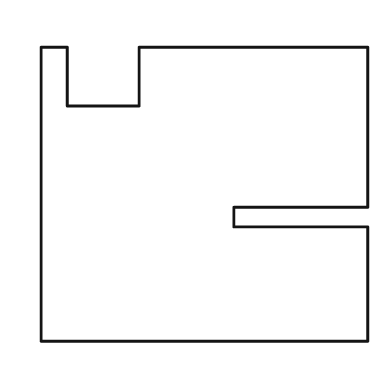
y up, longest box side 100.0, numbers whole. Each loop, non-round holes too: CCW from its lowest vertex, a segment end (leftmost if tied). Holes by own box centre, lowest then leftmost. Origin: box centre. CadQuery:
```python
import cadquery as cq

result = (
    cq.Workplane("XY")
    .moveTo(-50.0, -45.0)
    .lineTo(50.0, -45.0)
    .lineTo(50.0, -10.0)
    .lineTo(9.0, -10.0)
    .lineTo(9.0, -4.0)
    .lineTo(50.0, -4.0)
    .lineTo(50.0, 45.0)
    .lineTo(-20.0, 45.0)
    .lineTo(-20.0, 27.0)
    .lineTo(-42.0, 27.0)
    .lineTo(-42.0, 45.0)
    .lineTo(-50.0, 45.0)
    .close()
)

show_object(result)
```